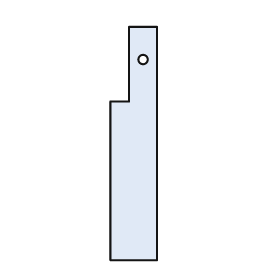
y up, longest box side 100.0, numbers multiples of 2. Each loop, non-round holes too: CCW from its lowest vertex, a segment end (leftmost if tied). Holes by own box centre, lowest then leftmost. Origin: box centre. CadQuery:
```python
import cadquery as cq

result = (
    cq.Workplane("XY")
    .moveTo(-10.0, -50.0)
    .lineTo(10.0, -50.0)
    .lineTo(10.0, 50.0)
    .lineTo(-2.0, 50.0)
    .lineTo(-2.0, 18.0)
    .lineTo(-10.0, 18.0)
    .close()
    .moveTo(4.0, 36.0)
    .circle(2.0)
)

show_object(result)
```